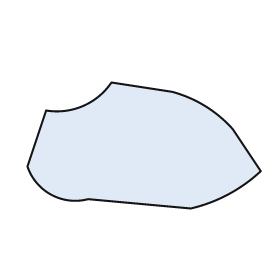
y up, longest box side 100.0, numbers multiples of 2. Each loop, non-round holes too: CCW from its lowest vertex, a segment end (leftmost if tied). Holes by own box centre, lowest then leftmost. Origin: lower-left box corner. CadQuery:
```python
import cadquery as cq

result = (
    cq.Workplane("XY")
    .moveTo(70.0, 0.0)
    .threePointArc((86.0, 6.0), (100.0, 16.0))
    .lineTo(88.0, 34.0)
    .threePointArc((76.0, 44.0), (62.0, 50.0))
    .lineTo(36.0, 54.0)
    .threePointArc((24.0, 44.0), (8.0, 42.0))
    .lineTo(0.0, 18.0)
    .threePointArc((10.0, 6.0), (26.0, 4.0))
    .close()
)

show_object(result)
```